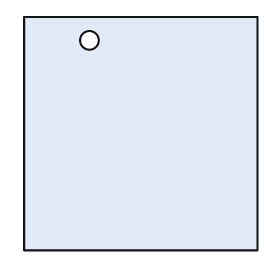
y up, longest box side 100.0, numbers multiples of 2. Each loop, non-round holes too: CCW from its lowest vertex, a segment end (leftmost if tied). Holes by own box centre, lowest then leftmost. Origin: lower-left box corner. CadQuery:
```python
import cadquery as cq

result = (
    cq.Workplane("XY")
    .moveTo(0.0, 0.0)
    .lineTo(100.0, 0.0)
    .lineTo(100.0, 100.0)
    .lineTo(0.0, 100.0)
    .close()
    .moveTo(28.0, 90.0)
    .circle(4.0)
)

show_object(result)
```